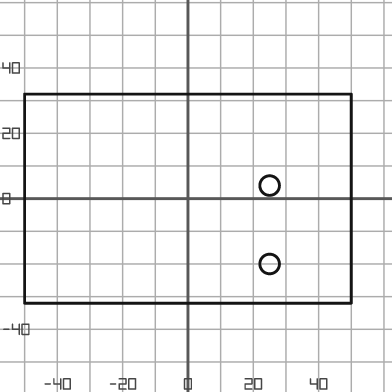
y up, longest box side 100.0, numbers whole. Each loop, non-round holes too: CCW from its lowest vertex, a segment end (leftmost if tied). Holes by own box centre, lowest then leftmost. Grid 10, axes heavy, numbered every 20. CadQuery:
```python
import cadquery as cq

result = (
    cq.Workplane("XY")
    .moveTo(-50.0, -32.0)
    .lineTo(50.0, -32.0)
    .lineTo(50.0, 32.0)
    .lineTo(-50.0, 32.0)
    .close()
    .moveTo(25.0, -20.0)
    .circle(3.0)
    .moveTo(25.0, 4.0)
    .circle(3.0)
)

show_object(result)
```